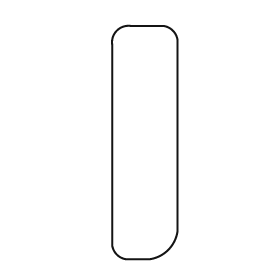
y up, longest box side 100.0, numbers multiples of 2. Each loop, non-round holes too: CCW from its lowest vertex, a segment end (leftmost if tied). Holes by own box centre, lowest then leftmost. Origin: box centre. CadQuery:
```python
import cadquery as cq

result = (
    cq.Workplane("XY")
    .moveTo(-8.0, -50.0)
    .lineTo(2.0, -50.0)
    .threePointArc((10.0, -46.0), (14.0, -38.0))
    .lineTo(14.0, 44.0)
    .threePointArc((12.0, 48.0), (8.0, 50.0))
    .lineTo(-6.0, 50.0)
    .threePointArc((-12.0, 48.0), (-14.0, 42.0))
    .lineTo(-14.0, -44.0)
    .threePointArc((-12.0, -48.0), (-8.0, -50.0))
    .close()
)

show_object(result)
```